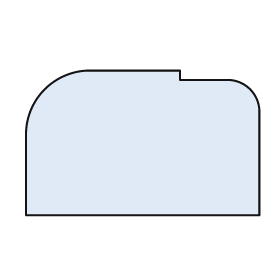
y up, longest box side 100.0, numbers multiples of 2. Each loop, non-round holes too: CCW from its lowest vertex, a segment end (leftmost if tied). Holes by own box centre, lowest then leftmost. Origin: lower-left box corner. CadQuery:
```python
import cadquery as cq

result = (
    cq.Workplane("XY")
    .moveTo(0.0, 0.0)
    .lineTo(100.0, 0.0)
    .lineTo(100.0, 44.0)
    .threePointArc((96.0, 54.0), (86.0, 58.0))
    .lineTo(66.0, 58.0)
    .lineTo(66.0, 62.0)
    .lineTo(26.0, 62.0)
    .threePointArc((8.0, 54.0), (0.0, 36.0))
    .close()
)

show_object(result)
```